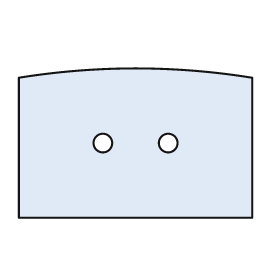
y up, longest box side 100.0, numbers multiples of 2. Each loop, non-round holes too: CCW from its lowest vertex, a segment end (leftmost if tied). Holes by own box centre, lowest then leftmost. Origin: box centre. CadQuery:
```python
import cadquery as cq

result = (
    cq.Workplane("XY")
    .moveTo(-50.0, -32.0)
    .lineTo(50.0, -32.0)
    .lineTo(50.0, 28.0)
    .threePointArc((0.0, 32.0), (-50.0, 28.0))
    .close()
    .moveTo(-14.0, 0.0)
    .circle(4.0)
    .moveTo(14.0, 0.0)
    .circle(4.0)
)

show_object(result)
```